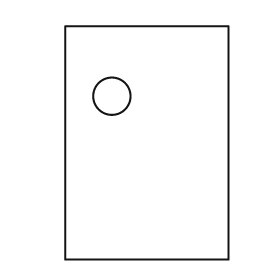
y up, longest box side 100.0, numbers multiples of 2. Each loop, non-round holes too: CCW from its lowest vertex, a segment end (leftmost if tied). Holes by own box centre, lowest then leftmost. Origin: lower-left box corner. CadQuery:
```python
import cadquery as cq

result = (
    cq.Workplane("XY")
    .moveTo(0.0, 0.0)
    .lineTo(70.0, 0.0)
    .lineTo(70.0, 100.0)
    .lineTo(0.0, 100.0)
    .close()
    .moveTo(20.0, 70.0)
    .circle(8.0)
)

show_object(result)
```